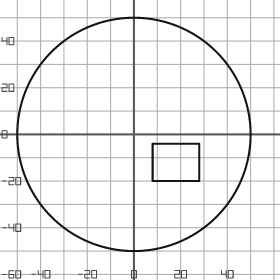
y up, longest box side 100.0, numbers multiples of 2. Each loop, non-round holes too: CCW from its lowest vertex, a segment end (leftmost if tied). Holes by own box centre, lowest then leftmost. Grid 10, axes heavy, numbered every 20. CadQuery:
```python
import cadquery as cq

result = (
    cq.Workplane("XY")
    .moveTo(0.0, 0.0)
    .circle(50.0)
    .moveTo(8.0, -20.0)
    .lineTo(28.0, -20.0)
    .lineTo(28.0, -4.0)
    .lineTo(8.0, -4.0)
    .close()
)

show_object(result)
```